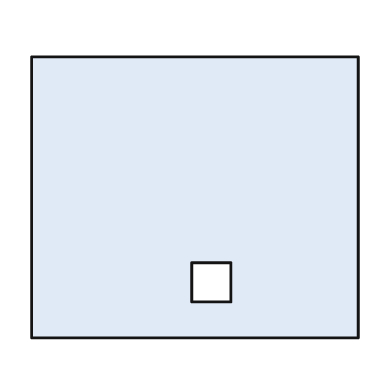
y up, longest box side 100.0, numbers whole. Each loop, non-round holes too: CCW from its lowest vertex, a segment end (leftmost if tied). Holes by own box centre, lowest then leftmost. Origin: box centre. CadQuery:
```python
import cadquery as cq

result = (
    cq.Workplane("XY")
    .moveTo(-50.0, -43.0)
    .lineTo(50.0, -43.0)
    .lineTo(50.0, 43.0)
    .lineTo(-50.0, 43.0)
    .close()
    .moveTo(-1.0, -32.0)
    .lineTo(11.0, -32.0)
    .lineTo(11.0, -20.0)
    .lineTo(-1.0, -20.0)
    .close()
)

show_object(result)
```